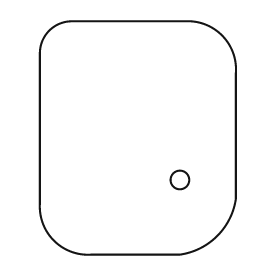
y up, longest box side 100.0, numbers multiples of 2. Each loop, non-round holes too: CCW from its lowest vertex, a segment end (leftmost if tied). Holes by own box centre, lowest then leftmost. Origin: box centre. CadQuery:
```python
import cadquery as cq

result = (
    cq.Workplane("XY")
    .moveTo(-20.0, -50.0)
    .lineTo(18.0, -50.0)
    .threePointArc((34.0, -42.0), (42.0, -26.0))
    .lineTo(42.0, 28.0)
    .threePointArc((36.0, 44.0), (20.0, 50.0))
    .lineTo(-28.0, 50.0)
    .threePointArc((-38.0, 46.0), (-42.0, 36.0))
    .lineTo(-42.0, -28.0)
    .threePointArc((-36.0, -44.0), (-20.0, -50.0))
    .close()
    .moveTo(18.0, -18.0)
    .circle(4.0)
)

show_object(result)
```